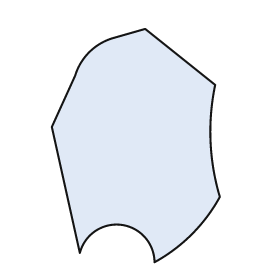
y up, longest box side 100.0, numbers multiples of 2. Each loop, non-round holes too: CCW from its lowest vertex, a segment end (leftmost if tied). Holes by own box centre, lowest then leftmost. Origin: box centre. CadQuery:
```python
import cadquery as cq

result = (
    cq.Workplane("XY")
    .moveTo(8.0, -50.0)
    .threePointArc((24.0, -38.0), (36.0, -22.0))
    .threePointArc((32.0, 2.0), (34.0, 26.0))
    .lineTo(4.0, 50.0)
    .lineTo(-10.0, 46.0)
    .threePointArc((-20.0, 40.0), (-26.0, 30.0))
    .lineTo(-36.0, 8.0)
    .lineTo(-24.0, -46.0)
    .threePointArc((-6.0, -34.0), (8.0, -50.0))
    .close()
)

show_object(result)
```